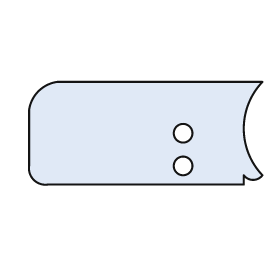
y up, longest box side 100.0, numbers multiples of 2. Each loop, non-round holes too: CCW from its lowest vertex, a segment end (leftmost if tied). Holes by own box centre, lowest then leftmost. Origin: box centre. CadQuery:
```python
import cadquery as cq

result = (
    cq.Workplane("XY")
    .moveTo(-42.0, -22.0)
    .lineTo(42.0, -22.0)
    .lineTo(42.0, -18.0)
    .threePointArc((46.0, -20.0), (50.0, -18.0))
    .threePointArc((42.0, 2.0), (50.0, 22.0))
    .lineTo(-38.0, 22.0)
    .threePointArc((-46.0, 18.0), (-50.0, 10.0))
    .lineTo(-50.0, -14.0)
    .threePointArc((-48.0, -20.0), (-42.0, -22.0))
    .close()
    .moveTo(16.0, -14.0)
    .circle(4.0)
    .moveTo(16.0, 0.0)
    .circle(4.0)
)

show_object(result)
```